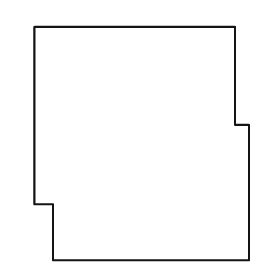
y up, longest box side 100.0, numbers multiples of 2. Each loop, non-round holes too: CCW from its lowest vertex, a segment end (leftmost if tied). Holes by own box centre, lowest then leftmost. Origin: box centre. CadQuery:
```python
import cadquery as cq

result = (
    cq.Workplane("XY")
    .moveTo(-38.0, -50.0)
    .lineTo(46.0, -50.0)
    .lineTo(46.0, 8.0)
    .lineTo(40.0, 8.0)
    .lineTo(40.0, 50.0)
    .lineTo(-46.0, 50.0)
    .lineTo(-46.0, -26.0)
    .lineTo(-38.0, -26.0)
    .close()
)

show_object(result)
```